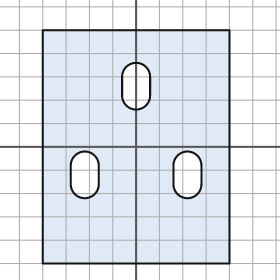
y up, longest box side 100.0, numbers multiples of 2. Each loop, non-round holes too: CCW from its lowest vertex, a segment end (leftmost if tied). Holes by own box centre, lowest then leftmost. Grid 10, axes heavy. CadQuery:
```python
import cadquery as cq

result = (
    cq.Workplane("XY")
    .moveTo(-40.0, -50.0)
    .lineTo(40.0, -50.0)
    .lineTo(40.0, 50.0)
    .lineTo(-40.0, 50.0)
    .close()
    .moveTo(-28.0, -16.0)
    .threePointArc((-22.0, -22.0), (-16.0, -16.0))
    .lineTo(-16.0, -8.0)
    .threePointArc((-22.0, -2.0), (-28.0, -8.0))
    .close()
    .moveTo(16.0, -16.0)
    .threePointArc((22.0, -22.0), (28.0, -16.0))
    .lineTo(28.0, -8.0)
    .threePointArc((22.0, -2.0), (16.0, -8.0))
    .close()
    .moveTo(-6.0, 22.0)
    .threePointArc((0.0, 16.0), (6.0, 22.0))
    .lineTo(6.0, 30.0)
    .threePointArc((0.0, 36.0), (-6.0, 30.0))
    .close()
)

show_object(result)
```